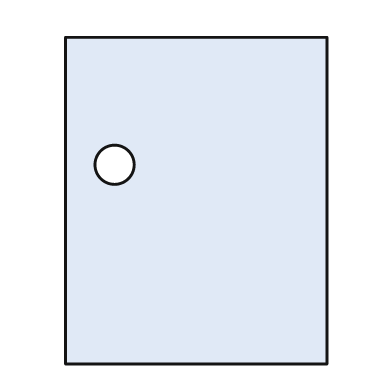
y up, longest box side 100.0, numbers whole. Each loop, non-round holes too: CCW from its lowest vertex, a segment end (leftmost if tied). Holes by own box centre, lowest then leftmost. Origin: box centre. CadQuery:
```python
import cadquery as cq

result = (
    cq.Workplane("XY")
    .moveTo(-40.0, -50.0)
    .lineTo(40.0, -50.0)
    .lineTo(40.0, 50.0)
    .lineTo(-40.0, 50.0)
    .close()
    .moveTo(-25.0, 11.0)
    .circle(6.0)
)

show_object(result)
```